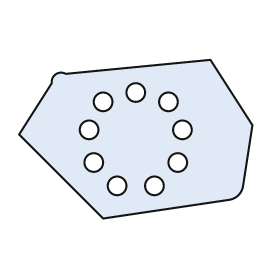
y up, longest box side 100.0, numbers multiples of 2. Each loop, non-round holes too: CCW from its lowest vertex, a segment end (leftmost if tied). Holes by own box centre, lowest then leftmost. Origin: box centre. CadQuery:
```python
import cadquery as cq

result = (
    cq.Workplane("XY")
    .moveTo(-14.0, -34.0)
    .lineTo(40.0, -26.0)
    .threePointArc((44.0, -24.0), (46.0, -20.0))
    .lineTo(50.0, 6.0)
    .lineTo(32.0, 34.0)
    .lineTo(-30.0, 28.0)
    .threePointArc((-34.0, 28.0), (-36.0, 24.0))
    .lineTo(-50.0, 2.0)
    .close()
    .moveTo(-8.0, -20.0)
    .circle(4.0)
    .moveTo(8.0, -20.0)
    .circle(4.0)
    .moveTo(-18.0, -10.0)
    .circle(4.0)
    .moveTo(18.0, -10.0)
    .circle(4.0)
    .moveTo(-20.0, 4.0)
    .circle(4.0)
    .moveTo(20.0, 4.0)
    .circle(4.0)
    .moveTo(-14.0, 16.0)
    .circle(4.0)
    .moveTo(14.0, 16.0)
    .circle(4.0)
    .moveTo(0.0, 20.0)
    .circle(4.0)
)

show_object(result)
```